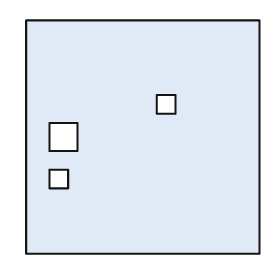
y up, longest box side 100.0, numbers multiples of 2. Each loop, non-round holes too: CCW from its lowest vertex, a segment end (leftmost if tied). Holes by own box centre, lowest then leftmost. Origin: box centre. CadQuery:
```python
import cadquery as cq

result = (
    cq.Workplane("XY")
    .moveTo(-50.0, -50.0)
    .lineTo(50.0, -50.0)
    .lineTo(50.0, 50.0)
    .lineTo(-50.0, 50.0)
    .close()
    .moveTo(-40.0, -22.0)
    .lineTo(-32.0, -22.0)
    .lineTo(-32.0, -14.0)
    .lineTo(-40.0, -14.0)
    .close()
    .moveTo(-40.0, -6.0)
    .lineTo(-28.0, -6.0)
    .lineTo(-28.0, 6.0)
    .lineTo(-40.0, 6.0)
    .close()
    .moveTo(6.0, 10.0)
    .lineTo(14.0, 10.0)
    .lineTo(14.0, 18.0)
    .lineTo(6.0, 18.0)
    .close()
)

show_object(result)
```